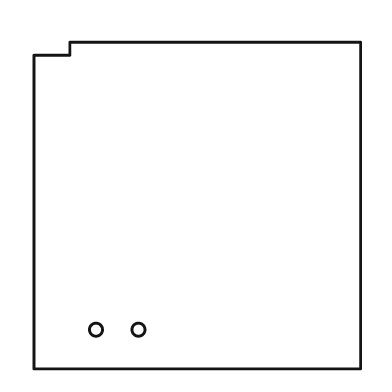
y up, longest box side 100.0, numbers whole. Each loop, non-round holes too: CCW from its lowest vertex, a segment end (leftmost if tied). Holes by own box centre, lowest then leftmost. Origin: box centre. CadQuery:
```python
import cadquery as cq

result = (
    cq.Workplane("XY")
    .moveTo(-50.0, -50.0)
    .lineTo(50.0, -50.0)
    .lineTo(50.0, 50.0)
    .lineTo(-39.0, 50.0)
    .lineTo(-39.0, 46.0)
    .lineTo(-50.0, 46.0)
    .close()
    .moveTo(-31.0, -38.0)
    .circle(2.0)
    .moveTo(-18.0, -38.0)
    .circle(2.0)
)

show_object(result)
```